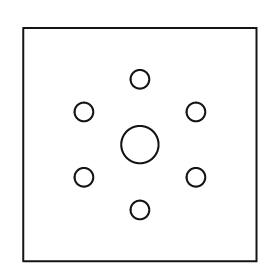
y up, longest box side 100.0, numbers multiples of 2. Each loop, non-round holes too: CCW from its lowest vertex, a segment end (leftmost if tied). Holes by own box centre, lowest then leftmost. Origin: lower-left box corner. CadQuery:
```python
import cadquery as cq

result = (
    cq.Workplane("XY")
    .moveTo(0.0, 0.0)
    .lineTo(100.0, 0.0)
    .lineTo(100.0, 100.0)
    .lineTo(0.0, 100.0)
    .close()
    .moveTo(50.0, 22.0)
    .circle(4.0)
    .moveTo(26.0, 36.0)
    .circle(4.0)
    .moveTo(74.0, 36.0)
    .circle(4.0)
    .moveTo(50.0, 50.0)
    .circle(8.0)
    .moveTo(26.0, 64.0)
    .circle(4.0)
    .moveTo(74.0, 64.0)
    .circle(4.0)
    .moveTo(50.0, 78.0)
    .circle(4.0)
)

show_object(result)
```